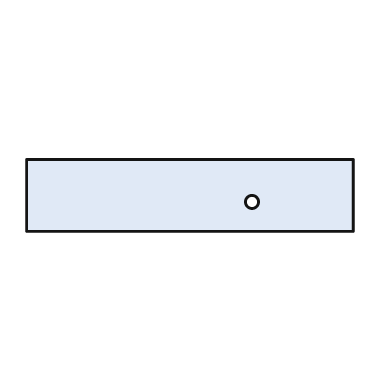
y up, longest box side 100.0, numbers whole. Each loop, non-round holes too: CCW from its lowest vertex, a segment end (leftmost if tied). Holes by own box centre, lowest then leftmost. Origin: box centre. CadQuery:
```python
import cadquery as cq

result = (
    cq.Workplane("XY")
    .moveTo(-50.0, -11.0)
    .lineTo(50.0, -11.0)
    .lineTo(50.0, 11.0)
    .lineTo(-50.0, 11.0)
    .close()
    .moveTo(19.0, -2.0)
    .circle(2.0)
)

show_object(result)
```